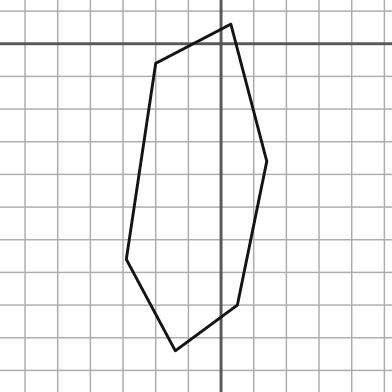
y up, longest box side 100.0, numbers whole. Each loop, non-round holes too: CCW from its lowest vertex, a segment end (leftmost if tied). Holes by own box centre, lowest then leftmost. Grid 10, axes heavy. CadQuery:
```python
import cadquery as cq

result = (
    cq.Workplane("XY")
    .moveTo(-14.0, -94.0)
    .lineTo(5.0, -80.0)
    .lineTo(14.0, -36.0)
    .lineTo(3.0, 6.0)
    .lineTo(-20.0, -6.0)
    .lineTo(-29.0, -66.0)
    .close()
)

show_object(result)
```